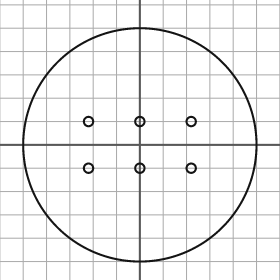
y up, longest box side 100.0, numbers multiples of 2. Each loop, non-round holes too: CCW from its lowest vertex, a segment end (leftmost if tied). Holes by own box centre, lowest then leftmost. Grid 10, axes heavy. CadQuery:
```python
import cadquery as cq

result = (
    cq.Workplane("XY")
    .moveTo(0.0, 0.0)
    .circle(50.0)
    .moveTo(-22.0, -10.0)
    .circle(2.0)
    .moveTo(0.0, -10.0)
    .circle(2.0)
    .moveTo(22.0, -10.0)
    .circle(2.0)
    .moveTo(-22.0, 10.0)
    .circle(2.0)
    .moveTo(0.0, 10.0)
    .circle(2.0)
    .moveTo(22.0, 10.0)
    .circle(2.0)
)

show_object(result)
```